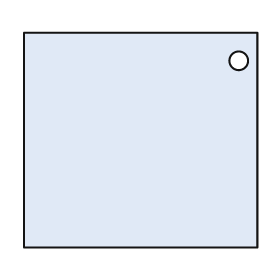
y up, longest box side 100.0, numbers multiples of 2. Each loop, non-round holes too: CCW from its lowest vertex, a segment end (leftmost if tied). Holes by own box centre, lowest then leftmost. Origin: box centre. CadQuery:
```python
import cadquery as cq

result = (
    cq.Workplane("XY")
    .moveTo(-50.0, -46.0)
    .lineTo(50.0, -46.0)
    .lineTo(50.0, 46.0)
    .lineTo(-50.0, 46.0)
    .close()
    .moveTo(42.0, 34.0)
    .circle(4.0)
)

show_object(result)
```